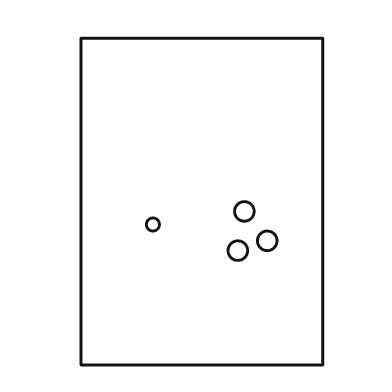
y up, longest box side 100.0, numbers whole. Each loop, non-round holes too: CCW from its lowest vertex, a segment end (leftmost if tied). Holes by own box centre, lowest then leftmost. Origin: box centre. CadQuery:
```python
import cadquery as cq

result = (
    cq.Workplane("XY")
    .moveTo(-37.0, -50.0)
    .lineTo(37.0, -50.0)
    .lineTo(37.0, 50.0)
    .lineTo(-37.0, 50.0)
    .close()
    .moveTo(11.0, -15.0)
    .circle(3.0)
    .moveTo(20.0, -12.0)
    .circle(3.0)
    .moveTo(-15.0, -7.0)
    .circle(2.0)
    .moveTo(13.0, -3.0)
    .circle(3.0)
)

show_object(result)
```